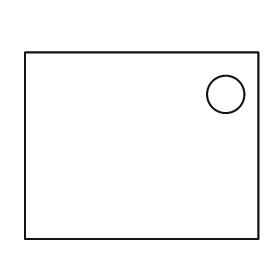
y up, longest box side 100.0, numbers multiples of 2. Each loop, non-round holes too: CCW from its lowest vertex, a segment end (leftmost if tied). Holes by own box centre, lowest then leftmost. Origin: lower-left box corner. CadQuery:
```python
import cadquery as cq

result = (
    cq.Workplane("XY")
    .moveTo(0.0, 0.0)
    .lineTo(100.0, 0.0)
    .lineTo(100.0, 80.0)
    .lineTo(0.0, 80.0)
    .close()
    .moveTo(86.0, 62.0)
    .circle(8.0)
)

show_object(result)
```